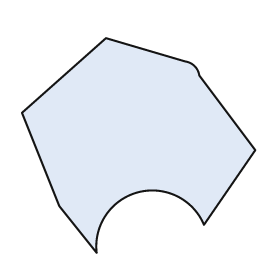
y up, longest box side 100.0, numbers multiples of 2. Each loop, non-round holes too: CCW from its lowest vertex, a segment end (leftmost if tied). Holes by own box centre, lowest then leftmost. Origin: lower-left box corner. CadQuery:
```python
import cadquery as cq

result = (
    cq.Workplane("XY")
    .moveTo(32.0, 0.0)
    .threePointArc((50.0, 26.0), (78.0, 12.0))
    .lineTo(100.0, 44.0)
    .lineTo(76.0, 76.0)
    .threePointArc((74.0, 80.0), (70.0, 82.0))
    .lineTo(36.0, 92.0)
    .lineTo(0.0, 60.0)
    .lineTo(16.0, 20.0)
    .close()
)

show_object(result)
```